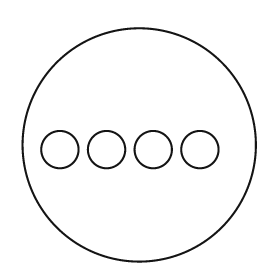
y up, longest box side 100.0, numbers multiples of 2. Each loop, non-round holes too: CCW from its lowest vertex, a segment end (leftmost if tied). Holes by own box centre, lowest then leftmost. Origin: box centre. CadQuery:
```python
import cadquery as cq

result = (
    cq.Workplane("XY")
    .moveTo(0.0, 0.0)
    .circle(50.0)
    .moveTo(-34.0, -2.0)
    .circle(8.0)
    .moveTo(-14.0, -2.0)
    .circle(8.0)
    .moveTo(6.0, -2.0)
    .circle(8.0)
    .moveTo(26.0, -2.0)
    .circle(8.0)
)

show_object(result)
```